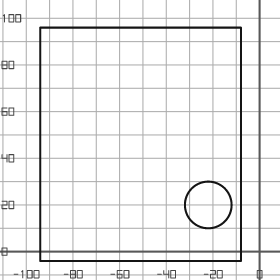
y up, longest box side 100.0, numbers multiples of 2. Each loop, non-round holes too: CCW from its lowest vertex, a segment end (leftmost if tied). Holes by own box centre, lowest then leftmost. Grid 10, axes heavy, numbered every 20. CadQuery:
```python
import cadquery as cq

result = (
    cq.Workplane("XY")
    .moveTo(-94.0, -4.0)
    .lineTo(-8.0, -4.0)
    .lineTo(-8.0, 96.0)
    .lineTo(-94.0, 96.0)
    .close()
    .moveTo(-22.0, 20.0)
    .circle(10.0)
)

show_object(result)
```